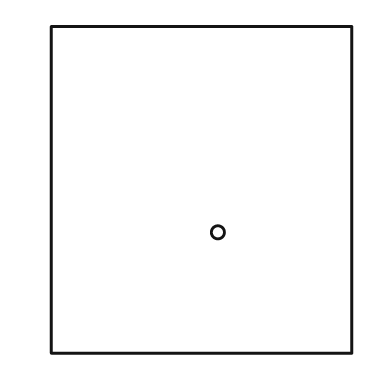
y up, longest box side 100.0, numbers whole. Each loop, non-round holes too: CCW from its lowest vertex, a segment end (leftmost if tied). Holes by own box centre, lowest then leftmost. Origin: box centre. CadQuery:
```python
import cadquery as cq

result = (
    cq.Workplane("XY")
    .moveTo(-46.0, -50.0)
    .lineTo(46.0, -50.0)
    .lineTo(46.0, 50.0)
    .lineTo(-46.0, 50.0)
    .close()
    .moveTo(5.0, -13.0)
    .circle(2.0)
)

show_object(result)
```